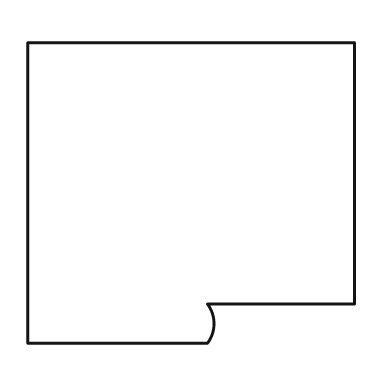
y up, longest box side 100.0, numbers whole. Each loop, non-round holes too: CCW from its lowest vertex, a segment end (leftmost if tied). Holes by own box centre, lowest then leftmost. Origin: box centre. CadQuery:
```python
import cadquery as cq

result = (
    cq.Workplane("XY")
    .moveTo(-50.0, -46.0)
    .lineTo(5.0, -46.0)
    .threePointArc((7.0, -40.0), (5.0, -34.0))
    .lineTo(50.0, -34.0)
    .lineTo(50.0, 46.0)
    .lineTo(-50.0, 46.0)
    .close()
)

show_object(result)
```